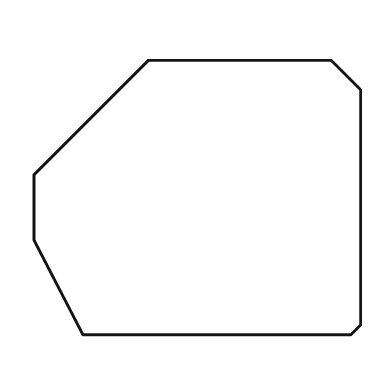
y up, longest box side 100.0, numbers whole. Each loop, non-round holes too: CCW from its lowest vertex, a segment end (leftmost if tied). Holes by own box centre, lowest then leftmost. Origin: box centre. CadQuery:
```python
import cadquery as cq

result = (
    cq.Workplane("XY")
    .moveTo(-35.0, -42.0)
    .lineTo(47.0, -42.0)
    .lineTo(50.0, -39.0)
    .lineTo(50.0, 33.0)
    .lineTo(41.0, 42.0)
    .lineTo(-15.0, 42.0)
    .lineTo(-50.0, 7.0)
    .lineTo(-50.0, -13.0)
    .close()
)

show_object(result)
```